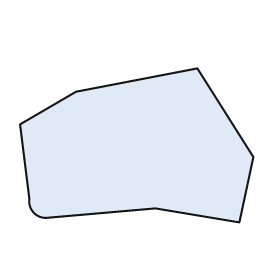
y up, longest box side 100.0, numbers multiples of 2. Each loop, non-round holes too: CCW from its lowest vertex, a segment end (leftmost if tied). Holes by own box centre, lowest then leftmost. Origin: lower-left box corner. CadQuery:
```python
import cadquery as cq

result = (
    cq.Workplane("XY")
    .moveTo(94.0, 0.0)
    .lineTo(100.0, 28.0)
    .lineTo(76.0, 66.0)
    .lineTo(24.0, 56.0)
    .lineTo(0.0, 42.0)
    .lineTo(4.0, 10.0)
    .threePointArc((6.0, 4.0), (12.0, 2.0))
    .lineTo(58.0, 6.0)
    .close()
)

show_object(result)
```